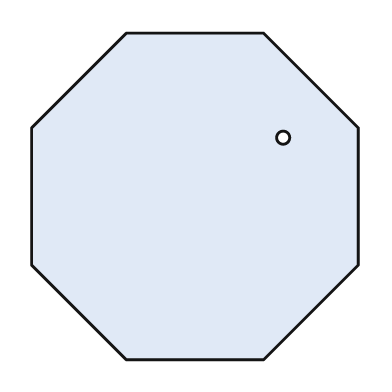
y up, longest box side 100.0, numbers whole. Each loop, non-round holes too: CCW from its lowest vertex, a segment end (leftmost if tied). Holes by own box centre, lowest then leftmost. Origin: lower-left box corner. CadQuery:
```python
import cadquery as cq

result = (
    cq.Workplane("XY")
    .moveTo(29.0, 0.0)
    .lineTo(71.0, 0.0)
    .lineTo(100.0, 29.0)
    .lineTo(100.0, 71.0)
    .lineTo(71.0, 100.0)
    .lineTo(29.0, 100.0)
    .lineTo(0.0, 71.0)
    .lineTo(0.0, 29.0)
    .close()
    .moveTo(77.0, 68.0)
    .circle(2.0)
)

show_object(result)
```